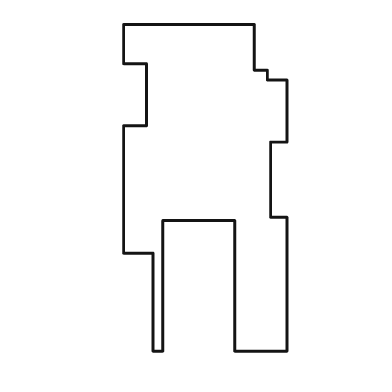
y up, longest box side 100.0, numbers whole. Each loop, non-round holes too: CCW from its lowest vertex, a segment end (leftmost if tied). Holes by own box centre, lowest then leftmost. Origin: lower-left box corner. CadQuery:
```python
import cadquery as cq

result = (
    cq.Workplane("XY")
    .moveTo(9.0, 0.0)
    .lineTo(12.0, 0.0)
    .lineTo(12.0, 40.0)
    .lineTo(34.0, 40.0)
    .lineTo(34.0, 0.0)
    .lineTo(50.0, 0.0)
    .lineTo(50.0, 41.0)
    .lineTo(45.0, 41.0)
    .lineTo(45.0, 64.0)
    .lineTo(50.0, 64.0)
    .lineTo(50.0, 83.0)
    .lineTo(44.0, 83.0)
    .lineTo(44.0, 86.0)
    .lineTo(40.0, 86.0)
    .lineTo(40.0, 100.0)
    .lineTo(0.0, 100.0)
    .lineTo(0.0, 88.0)
    .lineTo(7.0, 88.0)
    .lineTo(7.0, 69.0)
    .lineTo(0.0, 69.0)
    .lineTo(0.0, 30.0)
    .lineTo(9.0, 30.0)
    .close()
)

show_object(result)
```